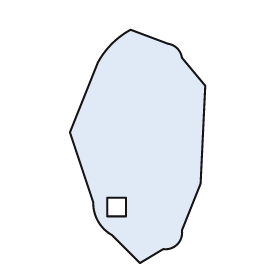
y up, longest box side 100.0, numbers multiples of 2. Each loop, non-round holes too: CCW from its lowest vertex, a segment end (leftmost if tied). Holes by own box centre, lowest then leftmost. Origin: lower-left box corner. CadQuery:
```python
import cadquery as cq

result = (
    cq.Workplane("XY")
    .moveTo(30.0, 0.0)
    .lineTo(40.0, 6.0)
    .threePointArc((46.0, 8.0), (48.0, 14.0))
    .lineTo(56.0, 34.0)
    .lineTo(58.0, 76.0)
    .lineTo(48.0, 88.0)
    .threePointArc((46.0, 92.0), (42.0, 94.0))
    .lineTo(26.0, 100.0)
    .threePointArc((18.0, 94.0), (12.0, 86.0))
    .lineTo(0.0, 56.0)
    .lineTo(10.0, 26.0)
    .threePointArc((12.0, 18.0), (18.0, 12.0))
    .close()
    .moveTo(16.0, 20.0)
    .lineTo(24.0, 20.0)
    .lineTo(24.0, 28.0)
    .lineTo(16.0, 28.0)
    .close()
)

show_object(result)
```